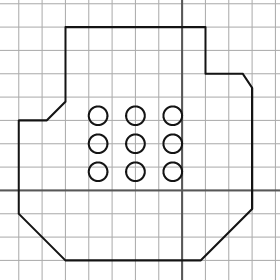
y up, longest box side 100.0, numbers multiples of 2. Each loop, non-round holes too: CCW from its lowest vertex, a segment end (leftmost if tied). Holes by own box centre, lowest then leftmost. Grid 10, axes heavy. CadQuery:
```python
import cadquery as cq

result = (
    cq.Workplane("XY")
    .moveTo(-50.0, -30.0)
    .lineTo(8.0, -30.0)
    .lineTo(30.0, -8.0)
    .lineTo(30.0, 44.0)
    .lineTo(26.0, 50.0)
    .lineTo(10.0, 50.0)
    .lineTo(10.0, 70.0)
    .lineTo(-50.0, 70.0)
    .lineTo(-50.0, 38.0)
    .lineTo(-58.0, 30.0)
    .lineTo(-70.0, 30.0)
    .lineTo(-70.0, -10.0)
    .close()
    .moveTo(-36.0, 8.0)
    .circle(4.0)
    .moveTo(-20.0, 8.0)
    .circle(4.0)
    .moveTo(-4.0, 8.0)
    .circle(4.0)
    .moveTo(-36.0, 20.0)
    .circle(4.0)
    .moveTo(-20.0, 20.0)
    .circle(4.0)
    .moveTo(-4.0, 20.0)
    .circle(4.0)
    .moveTo(-36.0, 32.0)
    .circle(4.0)
    .moveTo(-20.0, 32.0)
    .circle(4.0)
    .moveTo(-4.0, 32.0)
    .circle(4.0)
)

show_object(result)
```